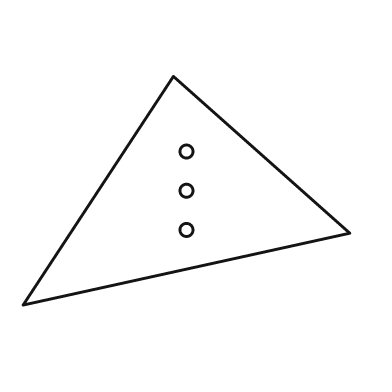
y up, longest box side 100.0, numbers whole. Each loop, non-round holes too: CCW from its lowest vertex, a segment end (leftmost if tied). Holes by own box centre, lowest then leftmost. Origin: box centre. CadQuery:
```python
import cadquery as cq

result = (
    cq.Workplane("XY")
    .moveTo(-50.0, -35.0)
    .lineTo(50.0, -13.0)
    .lineTo(-4.0, 35.0)
    .close()
    .moveTo(0.0, -12.0)
    .circle(2.0)
    .moveTo(0.0, 0.0)
    .circle(2.0)
    .moveTo(0.0, 12.0)
    .circle(2.0)
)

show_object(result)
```